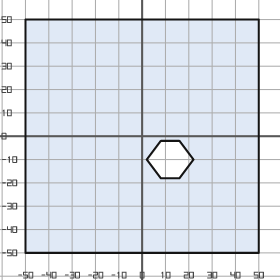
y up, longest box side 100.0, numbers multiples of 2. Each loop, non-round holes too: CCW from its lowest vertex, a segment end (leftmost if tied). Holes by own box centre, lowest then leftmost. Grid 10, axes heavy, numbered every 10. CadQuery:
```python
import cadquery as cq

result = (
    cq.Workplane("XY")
    .moveTo(-50.0, -50.0)
    .lineTo(50.0, -50.0)
    .lineTo(50.0, 50.0)
    .lineTo(-50.0, 50.0)
    .close()
    .moveTo(8.0, -18.0)
    .lineTo(16.0, -18.0)
    .lineTo(22.0, -10.0)
    .lineTo(16.0, -2.0)
    .lineTo(8.0, -2.0)
    .lineTo(2.0, -10.0)
    .close()
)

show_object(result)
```